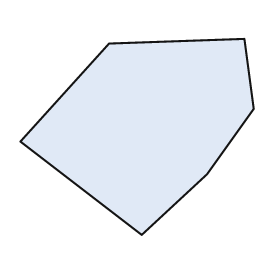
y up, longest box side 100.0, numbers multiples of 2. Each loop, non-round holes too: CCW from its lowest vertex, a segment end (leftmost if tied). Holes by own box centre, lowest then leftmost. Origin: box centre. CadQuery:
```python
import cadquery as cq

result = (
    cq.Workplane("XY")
    .moveTo(2.0, -42.0)
    .lineTo(30.0, -16.0)
    .lineTo(50.0, 12.0)
    .lineTo(46.0, 42.0)
    .lineTo(-12.0, 40.0)
    .lineTo(-50.0, -2.0)
    .close()
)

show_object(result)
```